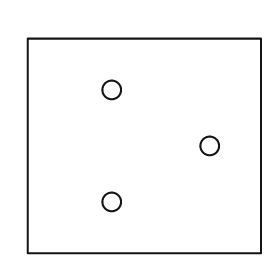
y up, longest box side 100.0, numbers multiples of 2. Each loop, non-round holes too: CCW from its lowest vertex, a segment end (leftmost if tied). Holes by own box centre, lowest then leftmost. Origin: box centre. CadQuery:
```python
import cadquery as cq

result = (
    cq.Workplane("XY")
    .moveTo(-50.0, -46.0)
    .lineTo(50.0, -46.0)
    .lineTo(50.0, 46.0)
    .lineTo(-50.0, 46.0)
    .close()
    .moveTo(-14.0, -24.0)
    .circle(4.0)
    .moveTo(28.0, 0.0)
    .circle(4.0)
    .moveTo(-14.0, 24.0)
    .circle(4.0)
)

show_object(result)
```